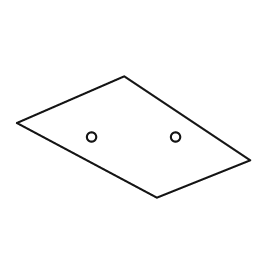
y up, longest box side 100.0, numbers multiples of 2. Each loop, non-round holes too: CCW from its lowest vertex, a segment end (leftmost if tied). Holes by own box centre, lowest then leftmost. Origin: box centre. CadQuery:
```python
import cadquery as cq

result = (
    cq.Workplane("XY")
    .moveTo(10.0, -26.0)
    .lineTo(50.0, -10.0)
    .lineTo(-4.0, 26.0)
    .lineTo(-50.0, 6.0)
    .close()
    .moveTo(-18.0, 0.0)
    .circle(2.0)
    .moveTo(18.0, 0.0)
    .circle(2.0)
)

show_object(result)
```